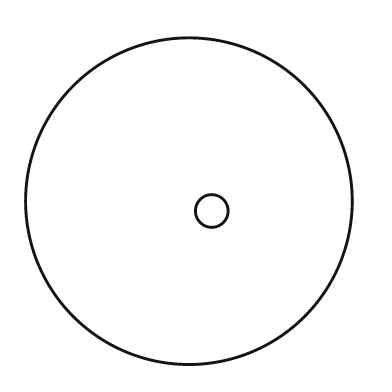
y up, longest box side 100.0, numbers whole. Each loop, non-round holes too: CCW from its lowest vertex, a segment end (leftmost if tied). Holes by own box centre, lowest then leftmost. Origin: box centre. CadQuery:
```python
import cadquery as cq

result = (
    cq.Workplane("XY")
    .moveTo(0.0, 0.0)
    .circle(50.0)
    .moveTo(7.0, -3.0)
    .circle(5.0)
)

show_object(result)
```